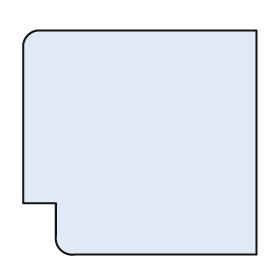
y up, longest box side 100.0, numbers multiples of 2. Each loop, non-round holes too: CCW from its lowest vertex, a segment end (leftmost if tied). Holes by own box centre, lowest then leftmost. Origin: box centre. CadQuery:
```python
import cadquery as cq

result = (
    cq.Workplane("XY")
    .moveTo(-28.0, -48.0)
    .lineTo(50.0, -48.0)
    .lineTo(50.0, 48.0)
    .lineTo(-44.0, 48.0)
    .threePointArc((-48.0, 46.0), (-50.0, 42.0))
    .lineTo(-50.0, -26.0)
    .lineTo(-36.0, -26.0)
    .lineTo(-36.0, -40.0)
    .threePointArc((-34.0, -46.0), (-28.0, -48.0))
    .close()
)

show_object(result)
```